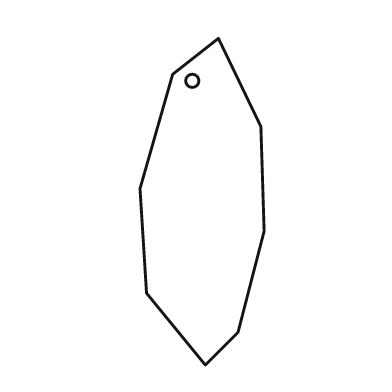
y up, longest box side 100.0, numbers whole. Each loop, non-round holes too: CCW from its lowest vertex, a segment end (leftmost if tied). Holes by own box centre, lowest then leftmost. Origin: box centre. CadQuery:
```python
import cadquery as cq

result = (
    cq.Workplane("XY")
    .moveTo(1.0, -50.0)
    .lineTo(11.0, -40.0)
    .lineTo(19.0, -9.0)
    .lineTo(18.0, 23.0)
    .lineTo(5.0, 50.0)
    .lineTo(-9.0, 39.0)
    .lineTo(-19.0, 4.0)
    .lineTo(-17.0, -28.0)
    .close()
    .moveTo(-3.0, 37.0)
    .circle(2.0)
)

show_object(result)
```